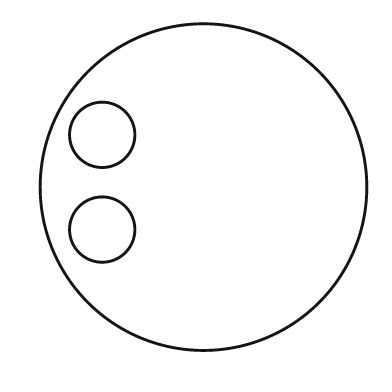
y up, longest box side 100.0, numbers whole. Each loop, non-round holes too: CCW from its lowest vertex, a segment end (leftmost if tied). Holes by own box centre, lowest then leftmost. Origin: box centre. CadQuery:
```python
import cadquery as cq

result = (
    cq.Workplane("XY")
    .moveTo(0.0, 0.0)
    .circle(50.0)
    .moveTo(-31.0, -13.0)
    .circle(10.0)
    .moveTo(-31.0, 16.0)
    .circle(10.0)
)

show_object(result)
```